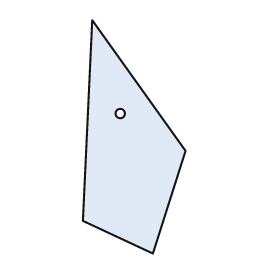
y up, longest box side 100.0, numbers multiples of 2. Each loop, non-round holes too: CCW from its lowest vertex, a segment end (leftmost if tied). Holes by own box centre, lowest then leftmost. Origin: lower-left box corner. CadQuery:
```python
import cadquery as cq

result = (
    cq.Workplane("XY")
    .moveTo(30.0, 0.0)
    .lineTo(44.0, 44.0)
    .lineTo(4.0, 100.0)
    .lineTo(0.0, 14.0)
    .close()
    .moveTo(16.0, 60.0)
    .circle(2.0)
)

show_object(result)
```